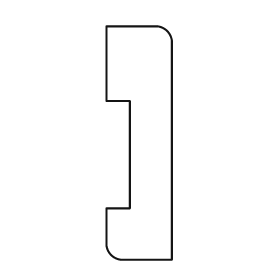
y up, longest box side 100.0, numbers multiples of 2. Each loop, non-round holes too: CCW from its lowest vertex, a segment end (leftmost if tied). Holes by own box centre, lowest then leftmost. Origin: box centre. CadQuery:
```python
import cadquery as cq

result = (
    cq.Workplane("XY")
    .moveTo(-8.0, -50.0)
    .lineTo(14.0, -50.0)
    .lineTo(14.0, 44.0)
    .threePointArc((12.0, 48.0), (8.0, 50.0))
    .lineTo(-14.0, 50.0)
    .lineTo(-14.0, 18.0)
    .lineTo(-4.0, 18.0)
    .lineTo(-4.0, -28.0)
    .lineTo(-14.0, -28.0)
    .lineTo(-14.0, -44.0)
    .threePointArc((-12.0, -48.0), (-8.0, -50.0))
    .close()
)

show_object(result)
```